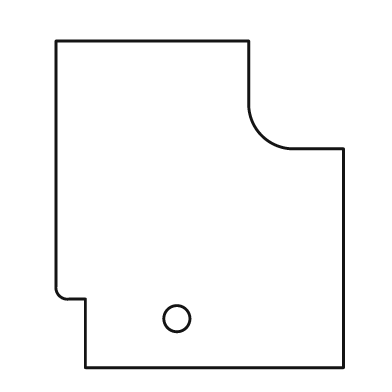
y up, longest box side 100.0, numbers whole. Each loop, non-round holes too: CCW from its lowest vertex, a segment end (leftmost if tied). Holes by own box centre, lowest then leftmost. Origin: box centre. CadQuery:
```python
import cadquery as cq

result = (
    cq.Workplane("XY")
    .moveTo(-35.0, -50.0)
    .lineTo(44.0, -50.0)
    .lineTo(44.0, 17.0)
    .lineTo(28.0, 17.0)
    .threePointArc((19.0, 21.0), (15.0, 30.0))
    .lineTo(15.0, 50.0)
    .lineTo(-44.0, 50.0)
    .lineTo(-44.0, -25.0)
    .threePointArc((-43.0, -28.0), (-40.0, -29.0))
    .lineTo(-35.0, -29.0)
    .close()
    .moveTo(-7.0, -35.0)
    .circle(4.0)
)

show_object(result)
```